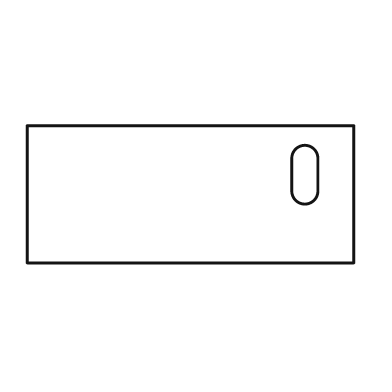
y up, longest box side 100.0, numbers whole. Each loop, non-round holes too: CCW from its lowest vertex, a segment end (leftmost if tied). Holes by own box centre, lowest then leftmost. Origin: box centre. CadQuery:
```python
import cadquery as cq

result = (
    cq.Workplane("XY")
    .moveTo(-50.0, -21.0)
    .lineTo(50.0, -21.0)
    .lineTo(50.0, 21.0)
    .lineTo(-50.0, 21.0)
    .close()
    .moveTo(31.0, 1.0)
    .threePointArc((35.0, -3.0), (39.0, 1.0))
    .lineTo(39.0, 11.0)
    .threePointArc((35.0, 15.0), (31.0, 11.0))
    .close()
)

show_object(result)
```